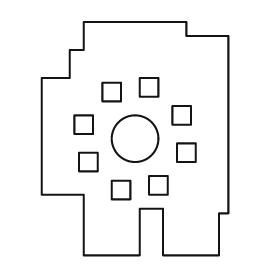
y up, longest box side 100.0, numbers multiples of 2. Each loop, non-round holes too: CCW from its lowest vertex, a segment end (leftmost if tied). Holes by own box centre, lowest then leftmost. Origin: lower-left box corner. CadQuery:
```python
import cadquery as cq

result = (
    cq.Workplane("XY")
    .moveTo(18.0, 0.0)
    .lineTo(42.0, 0.0)
    .lineTo(42.0, 20.0)
    .lineTo(52.0, 20.0)
    .lineTo(52.0, 0.0)
    .lineTo(76.0, 0.0)
    .lineTo(76.0, 18.0)
    .lineTo(80.0, 18.0)
    .lineTo(80.0, 94.0)
    .lineTo(62.0, 94.0)
    .lineTo(62.0, 100.0)
    .lineTo(18.0, 100.0)
    .lineTo(18.0, 88.0)
    .lineTo(12.0, 88.0)
    .lineTo(12.0, 76.0)
    .lineTo(0.0, 76.0)
    .lineTo(0.0, 26.0)
    .lineTo(18.0, 26.0)
    .close()
    .moveTo(30.0, 24.0)
    .lineTo(38.0, 24.0)
    .lineTo(38.0, 32.0)
    .lineTo(30.0, 32.0)
    .close()
    .moveTo(46.0, 26.0)
    .lineTo(54.0, 26.0)
    .lineTo(54.0, 34.0)
    .lineTo(46.0, 34.0)
    .close()
    .moveTo(16.0, 36.0)
    .lineTo(24.0, 36.0)
    .lineTo(24.0, 44.0)
    .lineTo(16.0, 44.0)
    .close()
    .moveTo(58.0, 40.0)
    .lineTo(66.0, 40.0)
    .lineTo(66.0, 48.0)
    .lineTo(58.0, 48.0)
    .close()
    .moveTo(40.0, 50.0)
    .circle(10.0)
    .moveTo(14.0, 52.0)
    .lineTo(22.0, 52.0)
    .lineTo(22.0, 60.0)
    .lineTo(14.0, 60.0)
    .close()
    .moveTo(56.0, 56.0)
    .lineTo(64.0, 56.0)
    .lineTo(64.0, 64.0)
    .lineTo(56.0, 64.0)
    .close()
    .moveTo(26.0, 66.0)
    .lineTo(34.0, 66.0)
    .lineTo(34.0, 74.0)
    .lineTo(26.0, 74.0)
    .close()
    .moveTo(42.0, 68.0)
    .lineTo(50.0, 68.0)
    .lineTo(50.0, 76.0)
    .lineTo(42.0, 76.0)
    .close()
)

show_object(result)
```